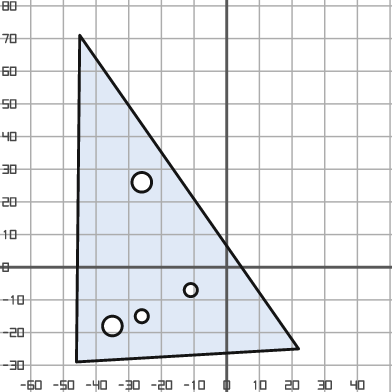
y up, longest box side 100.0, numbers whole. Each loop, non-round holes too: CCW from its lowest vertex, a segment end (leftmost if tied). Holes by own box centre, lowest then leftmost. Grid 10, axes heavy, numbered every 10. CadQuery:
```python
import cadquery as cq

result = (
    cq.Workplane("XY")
    .moveTo(-46.0, -29.0)
    .lineTo(22.0, -25.0)
    .lineTo(-45.0, 71.0)
    .close()
    .moveTo(-35.0, -18.0)
    .circle(3.0)
    .moveTo(-26.0, -15.0)
    .circle(2.0)
    .moveTo(-11.0, -7.0)
    .circle(2.0)
    .moveTo(-26.0, 26.0)
    .circle(3.0)
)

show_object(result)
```